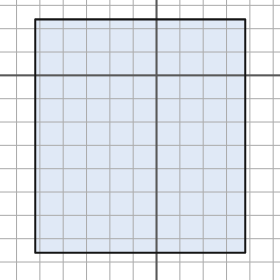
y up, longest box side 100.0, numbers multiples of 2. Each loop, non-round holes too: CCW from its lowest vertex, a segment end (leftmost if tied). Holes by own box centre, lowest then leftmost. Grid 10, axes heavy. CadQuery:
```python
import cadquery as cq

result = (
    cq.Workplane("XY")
    .moveTo(-52.0, -76.0)
    .lineTo(38.0, -76.0)
    .lineTo(38.0, 24.0)
    .lineTo(-52.0, 24.0)
    .close()
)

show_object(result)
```